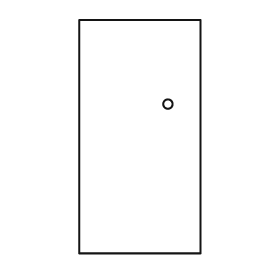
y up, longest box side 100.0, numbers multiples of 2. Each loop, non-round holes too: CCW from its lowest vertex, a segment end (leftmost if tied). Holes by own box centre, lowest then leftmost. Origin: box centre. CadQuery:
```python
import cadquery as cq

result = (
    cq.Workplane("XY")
    .moveTo(-26.0, -50.0)
    .lineTo(26.0, -50.0)
    .lineTo(26.0, 50.0)
    .lineTo(-26.0, 50.0)
    .close()
    .moveTo(12.0, 14.0)
    .circle(2.0)
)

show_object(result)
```